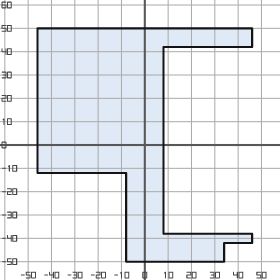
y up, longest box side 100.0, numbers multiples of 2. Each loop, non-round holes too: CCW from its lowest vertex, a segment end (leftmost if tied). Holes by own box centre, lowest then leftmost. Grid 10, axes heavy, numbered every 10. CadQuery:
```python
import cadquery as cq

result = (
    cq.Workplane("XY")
    .moveTo(-8.0, -50.0)
    .lineTo(34.0, -50.0)
    .lineTo(34.0, -42.0)
    .lineTo(46.0, -42.0)
    .lineTo(46.0, -38.0)
    .lineTo(8.0, -38.0)
    .lineTo(8.0, 42.0)
    .lineTo(46.0, 42.0)
    .lineTo(46.0, 50.0)
    .lineTo(-46.0, 50.0)
    .lineTo(-46.0, -12.0)
    .lineTo(-8.0, -12.0)
    .close()
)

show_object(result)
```